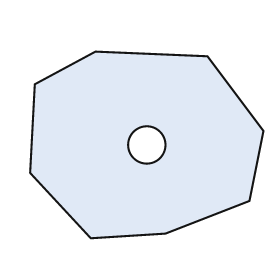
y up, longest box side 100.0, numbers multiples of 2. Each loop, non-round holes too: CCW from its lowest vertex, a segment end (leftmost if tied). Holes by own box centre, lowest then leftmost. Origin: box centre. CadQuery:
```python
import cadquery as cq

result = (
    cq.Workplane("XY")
    .moveTo(-24.0, -40.0)
    .lineTo(8.0, -38.0)
    .lineTo(44.0, -24.0)
    .lineTo(50.0, 6.0)
    .lineTo(26.0, 38.0)
    .lineTo(-22.0, 40.0)
    .lineTo(-48.0, 26.0)
    .lineTo(-50.0, -12.0)
    .close()
    .moveTo(0.0, 0.0)
    .circle(8.0)
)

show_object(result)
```